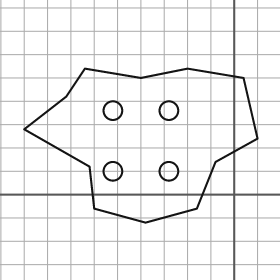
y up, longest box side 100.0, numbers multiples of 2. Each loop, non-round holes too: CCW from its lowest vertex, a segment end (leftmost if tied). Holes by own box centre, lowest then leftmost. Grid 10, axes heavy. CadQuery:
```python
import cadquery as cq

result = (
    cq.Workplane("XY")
    .moveTo(-38.0, -12.0)
    .lineTo(-16.0, -6.0)
    .lineTo(-8.0, 14.0)
    .lineTo(10.0, 24.0)
    .lineTo(4.0, 50.0)
    .lineTo(-20.0, 54.0)
    .lineTo(-40.0, 50.0)
    .lineTo(-64.0, 54.0)
    .lineTo(-72.0, 42.0)
    .lineTo(-90.0, 28.0)
    .lineTo(-62.0, 12.0)
    .lineTo(-60.0, -6.0)
    .close()
    .moveTo(-52.0, 10.0)
    .circle(4.0)
    .moveTo(-28.0, 10.0)
    .circle(4.0)
    .moveTo(-52.0, 36.0)
    .circle(4.0)
    .moveTo(-28.0, 36.0)
    .circle(4.0)
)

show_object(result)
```